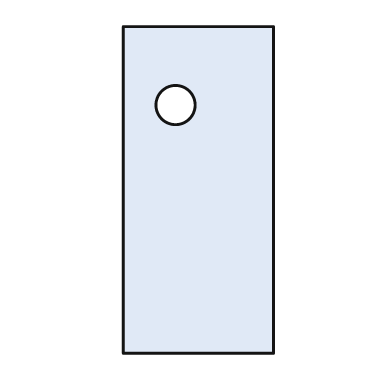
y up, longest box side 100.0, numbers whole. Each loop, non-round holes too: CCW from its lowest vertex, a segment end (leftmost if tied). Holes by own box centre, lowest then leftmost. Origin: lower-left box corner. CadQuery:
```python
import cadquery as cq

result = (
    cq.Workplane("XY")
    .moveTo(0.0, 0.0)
    .lineTo(46.0, 0.0)
    .lineTo(46.0, 100.0)
    .lineTo(0.0, 100.0)
    .close()
    .moveTo(16.0, 76.0)
    .circle(6.0)
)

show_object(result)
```